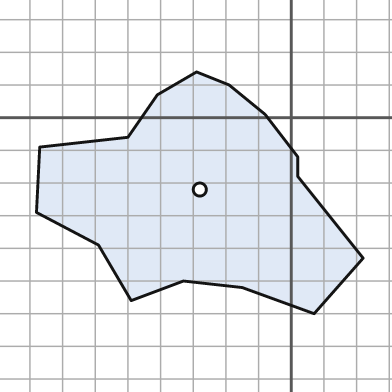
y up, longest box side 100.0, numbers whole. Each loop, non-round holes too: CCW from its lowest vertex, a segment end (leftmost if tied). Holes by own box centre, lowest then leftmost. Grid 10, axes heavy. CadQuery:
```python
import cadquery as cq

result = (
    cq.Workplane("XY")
    .moveTo(7.0, -60.0)
    .lineTo(22.0, -43.0)
    .lineTo(2.0, -18.0)
    .lineTo(2.0, -12.0)
    .lineTo(-8.0, 1.0)
    .lineTo(-19.0, 10.0)
    .lineTo(-29.0, 14.0)
    .lineTo(-41.0, 7.0)
    .lineTo(-50.0, -6.0)
    .lineTo(-77.0, -9.0)
    .lineTo(-78.0, -29.0)
    .lineTo(-59.0, -39.0)
    .lineTo(-49.0, -56.0)
    .lineTo(-33.0, -50.0)
    .lineTo(-15.0, -52.0)
    .close()
    .moveTo(-28.0, -22.0)
    .circle(2.0)
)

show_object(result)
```